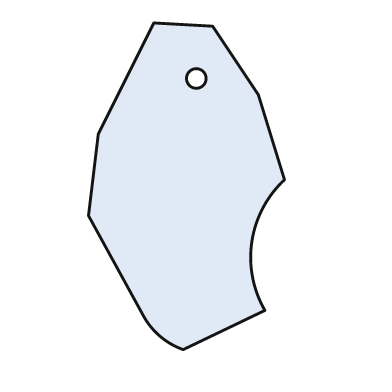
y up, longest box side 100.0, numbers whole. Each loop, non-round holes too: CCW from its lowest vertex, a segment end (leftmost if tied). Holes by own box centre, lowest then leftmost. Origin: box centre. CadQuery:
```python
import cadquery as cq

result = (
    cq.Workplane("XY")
    .moveTo(-1.0, -50.0)
    .lineTo(24.0, -38.0)
    .threePointArc((20.0, -17.0), (30.0, 2.0))
    .lineTo(22.0, 28.0)
    .lineTo(8.0, 49.0)
    .lineTo(-10.0, 50.0)
    .lineTo(-27.0, 16.0)
    .lineTo(-30.0, -9.0)
    .lineTo(-13.0, -40.0)
    .threePointArc((-8.0, -46.0), (-1.0, -50.0))
    .close()
    .moveTo(3.0, 33.0)
    .circle(3.0)
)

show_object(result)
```